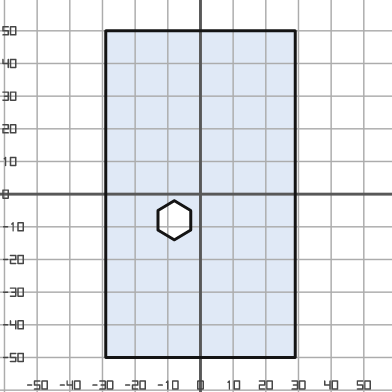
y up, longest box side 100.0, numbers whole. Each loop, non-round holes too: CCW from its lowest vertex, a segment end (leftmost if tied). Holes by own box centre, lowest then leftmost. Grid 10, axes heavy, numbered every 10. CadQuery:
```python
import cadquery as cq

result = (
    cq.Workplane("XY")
    .moveTo(-29.0, -50.0)
    .lineTo(29.0, -50.0)
    .lineTo(29.0, 50.0)
    .lineTo(-29.0, 50.0)
    .close()
    .moveTo(-8.0, -14.0)
    .lineTo(-3.0, -11.0)
    .lineTo(-3.0, -5.0)
    .lineTo(-8.0, -2.0)
    .lineTo(-13.0, -5.0)
    .lineTo(-13.0, -11.0)
    .close()
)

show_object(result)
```